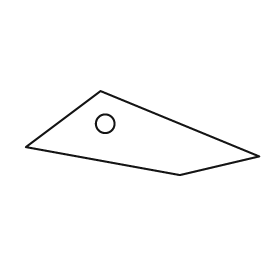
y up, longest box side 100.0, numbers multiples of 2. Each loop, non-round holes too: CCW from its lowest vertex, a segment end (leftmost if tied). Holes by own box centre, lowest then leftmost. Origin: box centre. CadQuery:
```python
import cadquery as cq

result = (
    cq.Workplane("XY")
    .moveTo(16.0, -18.0)
    .lineTo(50.0, -10.0)
    .lineTo(-18.0, 18.0)
    .lineTo(-50.0, -6.0)
    .close()
    .moveTo(-16.0, 4.0)
    .circle(4.0)
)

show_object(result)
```